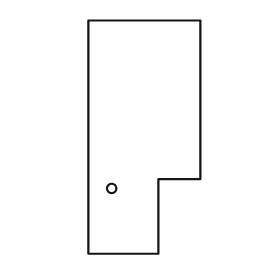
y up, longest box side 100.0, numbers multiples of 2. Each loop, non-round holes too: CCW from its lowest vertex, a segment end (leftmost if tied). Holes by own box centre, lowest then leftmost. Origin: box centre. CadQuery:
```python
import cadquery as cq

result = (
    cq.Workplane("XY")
    .moveTo(-24.0, -50.0)
    .lineTo(6.0, -50.0)
    .lineTo(6.0, -18.0)
    .lineTo(24.0, -18.0)
    .lineTo(24.0, 50.0)
    .lineTo(-24.0, 50.0)
    .close()
    .moveTo(-14.0, -22.0)
    .circle(2.0)
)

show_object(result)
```